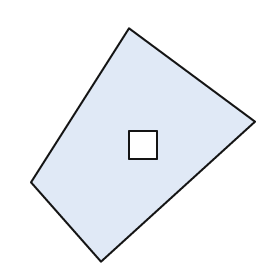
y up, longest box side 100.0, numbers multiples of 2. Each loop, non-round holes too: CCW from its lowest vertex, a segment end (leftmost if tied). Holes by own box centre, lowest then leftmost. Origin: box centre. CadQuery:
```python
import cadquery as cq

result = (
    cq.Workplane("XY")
    .moveTo(-18.0, -50.0)
    .lineTo(48.0, 10.0)
    .lineTo(-6.0, 50.0)
    .lineTo(-48.0, -16.0)
    .close()
    .moveTo(-6.0, -6.0)
    .lineTo(6.0, -6.0)
    .lineTo(6.0, 6.0)
    .lineTo(-6.0, 6.0)
    .close()
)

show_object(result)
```